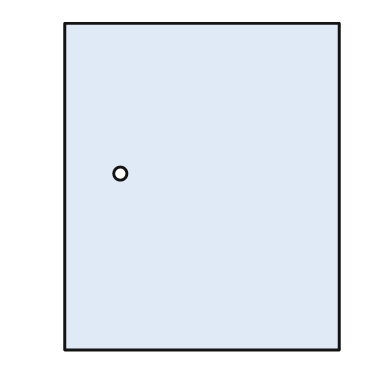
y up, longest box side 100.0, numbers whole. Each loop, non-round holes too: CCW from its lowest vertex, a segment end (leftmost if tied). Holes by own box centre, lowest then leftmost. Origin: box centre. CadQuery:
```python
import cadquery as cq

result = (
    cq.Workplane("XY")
    .moveTo(-42.0, -50.0)
    .lineTo(42.0, -50.0)
    .lineTo(42.0, 50.0)
    .lineTo(-42.0, 50.0)
    .close()
    .moveTo(-25.0, 4.0)
    .circle(2.0)
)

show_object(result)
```